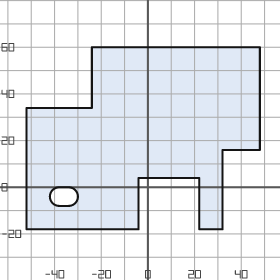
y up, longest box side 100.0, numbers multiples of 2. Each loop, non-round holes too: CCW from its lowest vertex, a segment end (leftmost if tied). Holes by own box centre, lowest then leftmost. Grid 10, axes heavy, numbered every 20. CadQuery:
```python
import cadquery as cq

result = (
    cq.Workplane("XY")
    .moveTo(-52.0, -18.0)
    .lineTo(-4.0, -18.0)
    .lineTo(-4.0, 4.0)
    .lineTo(22.0, 4.0)
    .lineTo(22.0, -18.0)
    .lineTo(32.0, -18.0)
    .lineTo(32.0, 16.0)
    .lineTo(48.0, 16.0)
    .lineTo(48.0, 60.0)
    .lineTo(-24.0, 60.0)
    .lineTo(-24.0, 34.0)
    .lineTo(-52.0, 34.0)
    .close()
    .moveTo(-38.0, -8.0)
    .lineTo(-34.0, -8.0)
    .threePointArc((-30.0, -4.0), (-34.0, 0.0))
    .lineTo(-38.0, 0.0)
    .threePointArc((-42.0, -4.0), (-38.0, -8.0))
    .close()
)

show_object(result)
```